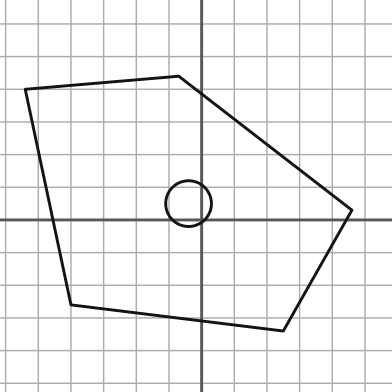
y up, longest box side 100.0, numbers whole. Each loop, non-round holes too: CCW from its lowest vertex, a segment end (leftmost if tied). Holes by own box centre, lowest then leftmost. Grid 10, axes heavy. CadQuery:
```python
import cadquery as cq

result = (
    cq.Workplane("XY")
    .moveTo(25.0, -34.0)
    .lineTo(46.0, 3.0)
    .lineTo(-7.0, 44.0)
    .lineTo(-54.0, 40.0)
    .lineTo(-40.0, -26.0)
    .close()
    .moveTo(-4.0, 5.0)
    .circle(7.0)
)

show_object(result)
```